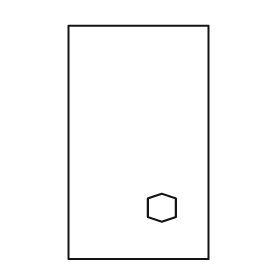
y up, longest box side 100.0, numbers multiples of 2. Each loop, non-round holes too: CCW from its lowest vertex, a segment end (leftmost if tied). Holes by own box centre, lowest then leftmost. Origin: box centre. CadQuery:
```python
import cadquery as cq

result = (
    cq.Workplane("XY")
    .moveTo(-30.0, -50.0)
    .lineTo(30.0, -50.0)
    .lineTo(30.0, 50.0)
    .lineTo(-30.0, 50.0)
    .close()
    .moveTo(10.0, -34.0)
    .lineTo(16.0, -32.0)
    .lineTo(16.0, -24.0)
    .lineTo(10.0, -22.0)
    .lineTo(4.0, -24.0)
    .lineTo(4.0, -32.0)
    .close()
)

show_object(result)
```